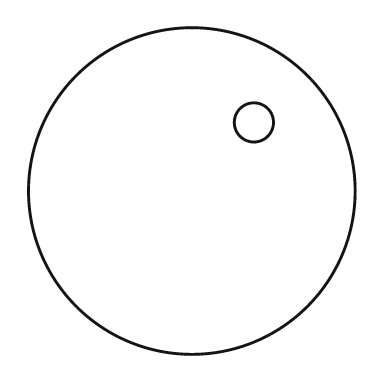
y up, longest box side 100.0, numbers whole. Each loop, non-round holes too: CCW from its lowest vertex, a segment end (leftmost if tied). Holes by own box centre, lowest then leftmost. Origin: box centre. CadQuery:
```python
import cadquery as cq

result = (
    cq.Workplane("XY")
    .moveTo(0.0, 0.0)
    .circle(50.0)
    .moveTo(19.0, 21.0)
    .circle(6.0)
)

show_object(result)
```